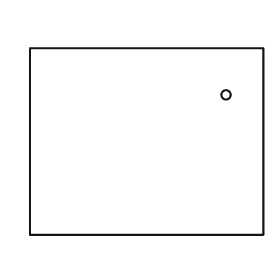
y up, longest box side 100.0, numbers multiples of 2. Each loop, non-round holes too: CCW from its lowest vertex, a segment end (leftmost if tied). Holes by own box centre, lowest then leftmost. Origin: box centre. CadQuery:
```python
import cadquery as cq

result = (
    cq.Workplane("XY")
    .moveTo(-50.0, -40.0)
    .lineTo(50.0, -40.0)
    .lineTo(50.0, 40.0)
    .lineTo(-50.0, 40.0)
    .close()
    .moveTo(34.0, 20.0)
    .circle(2.0)
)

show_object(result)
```